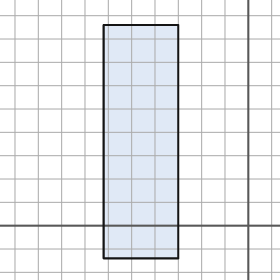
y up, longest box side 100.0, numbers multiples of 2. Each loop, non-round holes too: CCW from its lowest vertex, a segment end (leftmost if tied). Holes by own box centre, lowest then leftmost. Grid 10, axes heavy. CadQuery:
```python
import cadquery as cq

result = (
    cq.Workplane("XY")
    .moveTo(-62.0, -14.0)
    .lineTo(-30.0, -14.0)
    .lineTo(-30.0, 86.0)
    .lineTo(-62.0, 86.0)
    .close()
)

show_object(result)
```